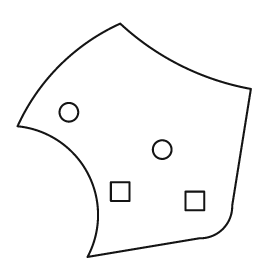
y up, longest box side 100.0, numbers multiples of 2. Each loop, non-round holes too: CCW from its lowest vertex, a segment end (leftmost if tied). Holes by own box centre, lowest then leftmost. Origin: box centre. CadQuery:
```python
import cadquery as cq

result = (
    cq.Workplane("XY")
    .moveTo(-20.0, -50.0)
    .lineTo(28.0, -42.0)
    .threePointArc((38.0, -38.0), (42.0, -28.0))
    .lineTo(50.0, 22.0)
    .threePointArc((20.0, 32.0), (-6.0, 50.0))
    .threePointArc((-32.0, 32.0), (-50.0, 6.0))
    .threePointArc((-20.0, -14.0), (-20.0, -50.0))
    .close()
    .moveTo(22.0, -30.0)
    .lineTo(30.0, -30.0)
    .lineTo(30.0, -22.0)
    .lineTo(22.0, -22.0)
    .close()
    .moveTo(-10.0, -26.0)
    .lineTo(-2.0, -26.0)
    .lineTo(-2.0, -18.0)
    .lineTo(-10.0, -18.0)
    .close()
    .moveTo(12.0, -4.0)
    .circle(4.0)
    .moveTo(-28.0, 12.0)
    .circle(4.0)
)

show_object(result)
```